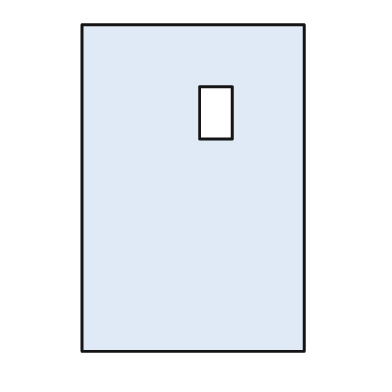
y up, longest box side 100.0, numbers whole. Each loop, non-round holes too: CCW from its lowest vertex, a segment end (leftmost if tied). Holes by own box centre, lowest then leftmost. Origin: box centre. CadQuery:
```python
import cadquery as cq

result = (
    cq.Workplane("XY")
    .moveTo(-34.0, -50.0)
    .lineTo(34.0, -50.0)
    .lineTo(34.0, 50.0)
    .lineTo(-34.0, 50.0)
    .close()
    .moveTo(2.0, 15.0)
    .lineTo(12.0, 15.0)
    .lineTo(12.0, 31.0)
    .lineTo(2.0, 31.0)
    .close()
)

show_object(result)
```